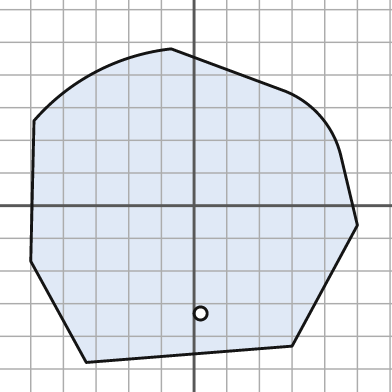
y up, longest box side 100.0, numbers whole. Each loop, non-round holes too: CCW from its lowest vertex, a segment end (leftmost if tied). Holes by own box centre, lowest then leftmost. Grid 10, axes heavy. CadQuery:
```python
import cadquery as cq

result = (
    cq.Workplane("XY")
    .moveTo(-33.0, -48.0)
    .lineTo(30.0, -43.0)
    .lineTo(50.0, -6.0)
    .lineTo(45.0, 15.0)
    .threePointArc((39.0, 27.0), (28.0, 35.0))
    .lineTo(-7.0, 48.0)
    .threePointArc((-30.0, 41.0), (-49.0, 26.0))
    .lineTo(-50.0, -17.0)
    .close()
    .moveTo(2.0, -33.0)
    .circle(2.0)
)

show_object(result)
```